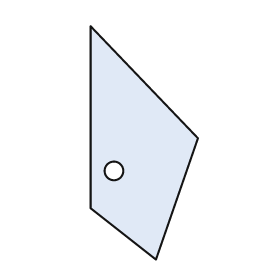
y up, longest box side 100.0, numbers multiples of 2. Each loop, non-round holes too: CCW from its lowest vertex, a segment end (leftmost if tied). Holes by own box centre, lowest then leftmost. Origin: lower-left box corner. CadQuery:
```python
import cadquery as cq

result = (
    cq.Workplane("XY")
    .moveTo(28.0, 0.0)
    .lineTo(46.0, 52.0)
    .lineTo(0.0, 100.0)
    .lineTo(0.0, 22.0)
    .close()
    .moveTo(10.0, 38.0)
    .circle(4.0)
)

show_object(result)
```